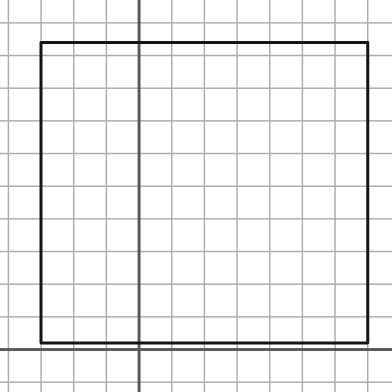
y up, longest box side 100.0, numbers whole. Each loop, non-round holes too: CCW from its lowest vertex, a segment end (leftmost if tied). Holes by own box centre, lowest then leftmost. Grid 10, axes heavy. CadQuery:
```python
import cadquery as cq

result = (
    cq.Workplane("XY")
    .moveTo(-30.0, 2.0)
    .lineTo(70.0, 2.0)
    .lineTo(70.0, 94.0)
    .lineTo(-30.0, 94.0)
    .close()
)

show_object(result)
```